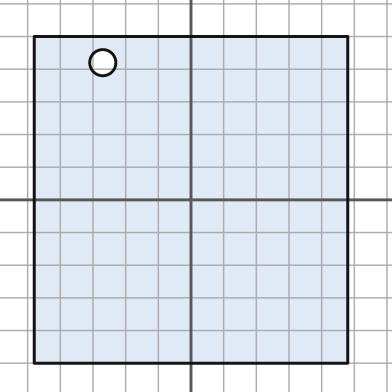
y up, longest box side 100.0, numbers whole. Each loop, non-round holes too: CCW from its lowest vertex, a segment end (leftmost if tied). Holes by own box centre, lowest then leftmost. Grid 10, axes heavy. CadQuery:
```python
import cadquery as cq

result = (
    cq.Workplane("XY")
    .moveTo(-48.0, -50.0)
    .lineTo(48.0, -50.0)
    .lineTo(48.0, 50.0)
    .lineTo(-48.0, 50.0)
    .close()
    .moveTo(-27.0, 42.0)
    .circle(4.0)
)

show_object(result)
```